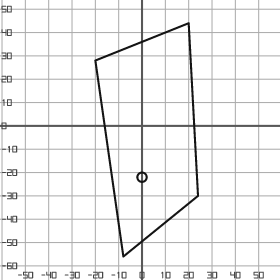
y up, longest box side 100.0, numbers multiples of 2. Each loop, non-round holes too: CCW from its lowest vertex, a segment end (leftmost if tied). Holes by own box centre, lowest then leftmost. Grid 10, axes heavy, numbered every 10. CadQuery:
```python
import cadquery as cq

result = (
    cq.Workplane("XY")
    .moveTo(-8.0, -56.0)
    .lineTo(24.0, -30.0)
    .lineTo(20.0, 44.0)
    .lineTo(-20.0, 28.0)
    .close()
    .moveTo(0.0, -22.0)
    .circle(2.0)
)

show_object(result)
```